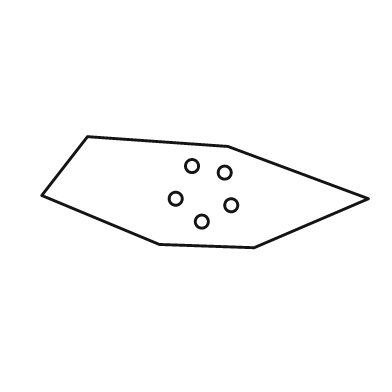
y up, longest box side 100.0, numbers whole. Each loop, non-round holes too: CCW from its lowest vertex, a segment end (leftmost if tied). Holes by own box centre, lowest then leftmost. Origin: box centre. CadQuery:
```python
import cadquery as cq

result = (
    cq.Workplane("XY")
    .moveTo(15.0, -17.0)
    .lineTo(50.0, -2.0)
    .lineTo(7.0, 14.0)
    .lineTo(-36.0, 17.0)
    .lineTo(-50.0, -1.0)
    .lineTo(-14.0, -16.0)
    .close()
    .moveTo(-1.0, -9.0)
    .circle(2.0)
    .moveTo(8.0, -4.0)
    .circle(2.0)
    .moveTo(-9.0, -2.0)
    .circle(2.0)
    .moveTo(6.0, 6.0)
    .circle(2.0)
    .moveTo(-4.0, 8.0)
    .circle(2.0)
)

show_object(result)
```